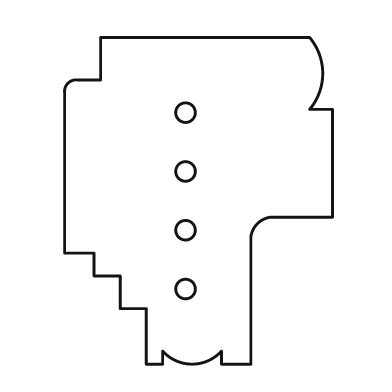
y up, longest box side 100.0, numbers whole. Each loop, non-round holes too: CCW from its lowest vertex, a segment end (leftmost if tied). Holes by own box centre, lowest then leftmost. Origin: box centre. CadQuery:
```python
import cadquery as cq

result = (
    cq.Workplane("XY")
    .moveTo(-16.0, -50.0)
    .lineTo(-11.0, -50.0)
    .lineTo(-11.0, -46.0)
    .threePointArc((-2.0, -50.0), (7.0, -46.0))
    .lineTo(7.0, -50.0)
    .lineTo(16.0, -50.0)
    .lineTo(16.0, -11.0)
    .threePointArc((18.0, -7.0), (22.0, -5.0))
    .lineTo(41.0, -5.0)
    .lineTo(41.0, 28.0)
    .lineTo(34.0, 28.0)
    .threePointArc((38.0, 39.0), (34.0, 50.0))
    .lineTo(-30.0, 50.0)
    .lineTo(-30.0, 37.0)
    .lineTo(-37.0, 37.0)
    .threePointArc((-40.0, 36.0), (-41.0, 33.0))
    .lineTo(-41.0, -16.0)
    .lineTo(-32.0, -16.0)
    .lineTo(-32.0, -23.0)
    .lineTo(-24.0, -23.0)
    .lineTo(-24.0, -33.0)
    .lineTo(-16.0, -33.0)
    .close()
    .moveTo(-4.0, -27.0)
    .circle(3.0)
    .moveTo(-4.0, -9.0)
    .circle(3.0)
    .moveTo(-4.0, 9.0)
    .circle(3.0)
    .moveTo(-4.0, 27.0)
    .circle(3.0)
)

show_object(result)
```